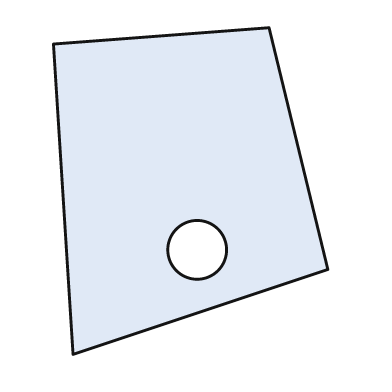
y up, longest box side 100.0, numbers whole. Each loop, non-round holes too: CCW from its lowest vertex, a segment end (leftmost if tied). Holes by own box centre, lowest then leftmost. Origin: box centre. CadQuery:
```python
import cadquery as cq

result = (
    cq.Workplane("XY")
    .moveTo(-36.0, -50.0)
    .lineTo(42.0, -24.0)
    .lineTo(24.0, 50.0)
    .lineTo(-42.0, 45.0)
    .close()
    .moveTo(2.0, -18.0)
    .circle(9.0)
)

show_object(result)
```